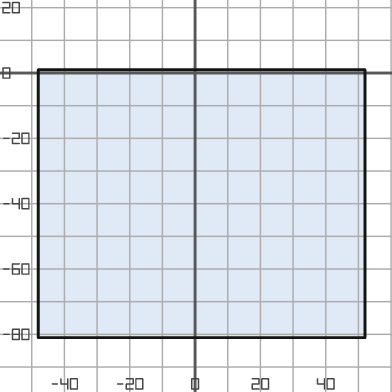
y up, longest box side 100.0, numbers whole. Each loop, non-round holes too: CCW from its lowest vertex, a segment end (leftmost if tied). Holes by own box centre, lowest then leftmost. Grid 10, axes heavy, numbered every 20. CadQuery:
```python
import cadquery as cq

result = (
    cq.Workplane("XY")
    .moveTo(-48.0, -81.0)
    .lineTo(52.0, -81.0)
    .lineTo(52.0, 1.0)
    .lineTo(-48.0, 1.0)
    .close()
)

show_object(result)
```